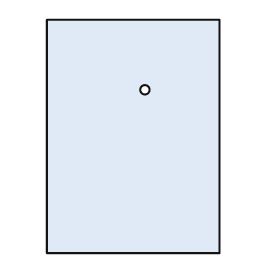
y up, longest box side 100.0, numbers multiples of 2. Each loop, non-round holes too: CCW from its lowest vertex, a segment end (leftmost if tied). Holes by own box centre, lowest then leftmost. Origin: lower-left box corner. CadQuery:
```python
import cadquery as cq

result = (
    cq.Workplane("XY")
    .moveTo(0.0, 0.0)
    .lineTo(74.0, 0.0)
    .lineTo(74.0, 100.0)
    .lineTo(0.0, 100.0)
    .close()
    .moveTo(42.0, 70.0)
    .circle(2.0)
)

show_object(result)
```